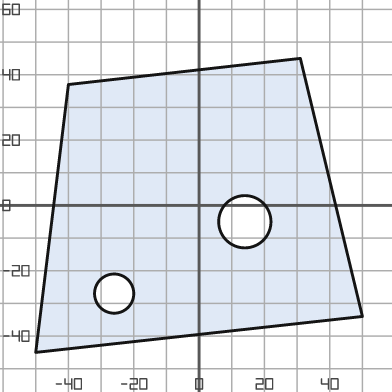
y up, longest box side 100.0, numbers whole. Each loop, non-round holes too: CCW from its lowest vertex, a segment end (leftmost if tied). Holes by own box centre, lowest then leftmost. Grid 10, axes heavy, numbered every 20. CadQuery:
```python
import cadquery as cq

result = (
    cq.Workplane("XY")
    .moveTo(-50.0, -45.0)
    .lineTo(50.0, -34.0)
    .lineTo(31.0, 45.0)
    .lineTo(-40.0, 37.0)
    .close()
    .moveTo(-26.0, -27.0)
    .circle(6.0)
    .moveTo(14.0, -5.0)
    .circle(8.0)
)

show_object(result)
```